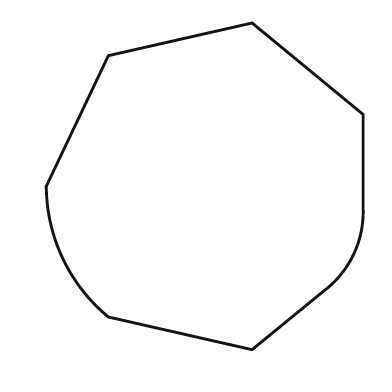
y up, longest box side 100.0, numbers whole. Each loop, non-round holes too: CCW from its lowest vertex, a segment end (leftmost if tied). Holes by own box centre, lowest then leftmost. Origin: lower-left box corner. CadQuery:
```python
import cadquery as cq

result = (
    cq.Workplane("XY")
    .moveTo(63.0, 0.0)
    .lineTo(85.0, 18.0)
    .threePointArc((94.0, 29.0), (97.0, 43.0))
    .lineTo(97.0, 72.0)
    .lineTo(63.0, 100.0)
    .lineTo(19.0, 90.0)
    .lineTo(0.0, 50.0)
    .threePointArc((5.0, 28.0), (19.0, 10.0))
    .close()
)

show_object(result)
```